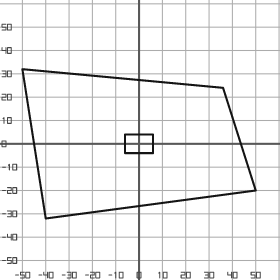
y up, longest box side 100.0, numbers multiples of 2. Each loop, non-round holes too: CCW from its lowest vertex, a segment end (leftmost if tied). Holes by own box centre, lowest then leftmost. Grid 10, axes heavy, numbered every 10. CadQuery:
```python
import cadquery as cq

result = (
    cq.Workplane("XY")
    .moveTo(-40.0, -32.0)
    .lineTo(50.0, -20.0)
    .lineTo(36.0, 24.0)
    .lineTo(-50.0, 32.0)
    .close()
    .moveTo(-6.0, -4.0)
    .lineTo(6.0, -4.0)
    .lineTo(6.0, 4.0)
    .lineTo(-6.0, 4.0)
    .close()
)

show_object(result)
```